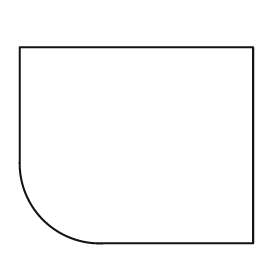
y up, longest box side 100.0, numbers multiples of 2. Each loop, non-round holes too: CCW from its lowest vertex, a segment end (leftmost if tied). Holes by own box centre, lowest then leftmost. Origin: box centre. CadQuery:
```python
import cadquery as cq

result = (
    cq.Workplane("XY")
    .moveTo(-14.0, -42.0)
    .lineTo(50.0, -42.0)
    .lineTo(50.0, 42.0)
    .lineTo(-50.0, 42.0)
    .lineTo(-50.0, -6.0)
    .threePointArc((-40.0, -32.0), (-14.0, -42.0))
    .close()
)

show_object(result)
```